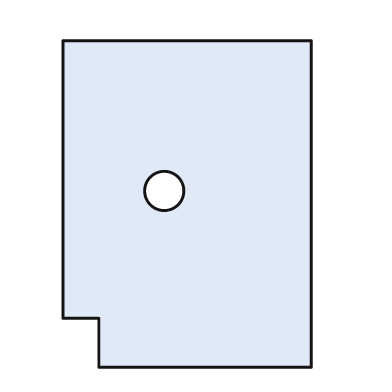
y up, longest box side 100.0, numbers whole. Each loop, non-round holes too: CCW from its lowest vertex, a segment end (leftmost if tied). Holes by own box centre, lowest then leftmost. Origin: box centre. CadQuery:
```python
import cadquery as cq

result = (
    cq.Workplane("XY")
    .moveTo(-27.0, -50.0)
    .lineTo(38.0, -50.0)
    .lineTo(38.0, 50.0)
    .lineTo(-38.0, 50.0)
    .lineTo(-38.0, -35.0)
    .lineTo(-27.0, -35.0)
    .close()
    .moveTo(-7.0, 4.0)
    .circle(6.0)
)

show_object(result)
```